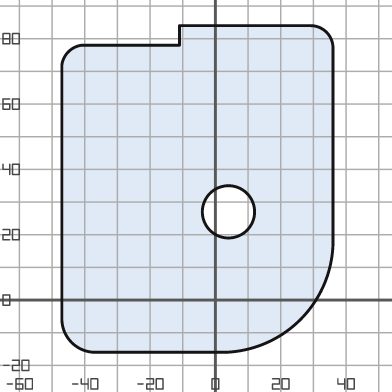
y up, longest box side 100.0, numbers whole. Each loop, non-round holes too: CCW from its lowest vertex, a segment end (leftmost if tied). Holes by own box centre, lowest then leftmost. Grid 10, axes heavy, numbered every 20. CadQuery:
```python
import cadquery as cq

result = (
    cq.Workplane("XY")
    .moveTo(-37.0, -16.0)
    .lineTo(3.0, -16.0)
    .threePointArc((26.0, -6.0), (36.0, 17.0))
    .lineTo(36.0, 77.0)
    .threePointArc((34.0, 82.0), (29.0, 84.0))
    .lineTo(-11.0, 84.0)
    .lineTo(-11.0, 78.0)
    .lineTo(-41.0, 78.0)
    .threePointArc((-45.0, 76.0), (-47.0, 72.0))
    .lineTo(-47.0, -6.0)
    .threePointArc((-44.0, -13.0), (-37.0, -16.0))
    .close()
    .moveTo(4.0, 27.0)
    .circle(8.0)
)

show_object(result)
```